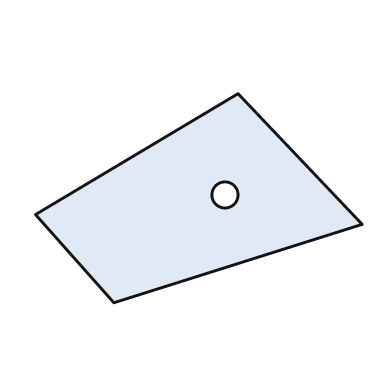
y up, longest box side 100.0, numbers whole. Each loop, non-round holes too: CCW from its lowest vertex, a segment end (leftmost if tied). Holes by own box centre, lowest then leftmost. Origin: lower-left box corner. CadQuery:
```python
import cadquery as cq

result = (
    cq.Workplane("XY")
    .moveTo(24.0, 0.0)
    .lineTo(100.0, 24.0)
    .lineTo(62.0, 64.0)
    .lineTo(0.0, 27.0)
    .close()
    .moveTo(58.0, 33.0)
    .circle(4.0)
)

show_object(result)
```